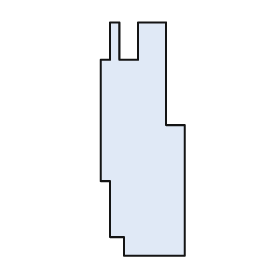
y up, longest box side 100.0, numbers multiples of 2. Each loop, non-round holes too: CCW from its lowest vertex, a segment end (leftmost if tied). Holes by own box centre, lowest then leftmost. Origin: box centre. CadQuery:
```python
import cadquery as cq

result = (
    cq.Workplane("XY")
    .moveTo(-8.0, -50.0)
    .lineTo(18.0, -50.0)
    .lineTo(18.0, 6.0)
    .lineTo(10.0, 6.0)
    .lineTo(10.0, 50.0)
    .lineTo(-2.0, 50.0)
    .lineTo(-2.0, 34.0)
    .lineTo(-10.0, 34.0)
    .lineTo(-10.0, 50.0)
    .lineTo(-14.0, 50.0)
    .lineTo(-14.0, 34.0)
    .lineTo(-18.0, 34.0)
    .lineTo(-18.0, -18.0)
    .lineTo(-14.0, -18.0)
    .lineTo(-14.0, -42.0)
    .lineTo(-8.0, -42.0)
    .close()
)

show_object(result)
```